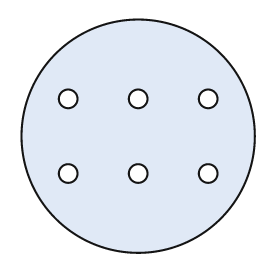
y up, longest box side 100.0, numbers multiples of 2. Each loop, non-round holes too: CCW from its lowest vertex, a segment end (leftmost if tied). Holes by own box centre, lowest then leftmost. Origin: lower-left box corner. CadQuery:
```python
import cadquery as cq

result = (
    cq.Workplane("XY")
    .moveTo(50.0, 50.0)
    .circle(50.0)
    .moveTo(20.0, 34.0)
    .circle(4.0)
    .moveTo(50.0, 34.0)
    .circle(4.0)
    .moveTo(80.0, 34.0)
    .circle(4.0)
    .moveTo(20.0, 66.0)
    .circle(4.0)
    .moveTo(50.0, 66.0)
    .circle(4.0)
    .moveTo(80.0, 66.0)
    .circle(4.0)
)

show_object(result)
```